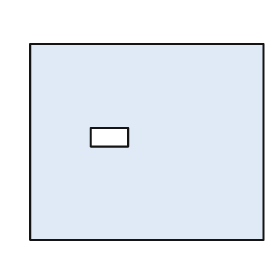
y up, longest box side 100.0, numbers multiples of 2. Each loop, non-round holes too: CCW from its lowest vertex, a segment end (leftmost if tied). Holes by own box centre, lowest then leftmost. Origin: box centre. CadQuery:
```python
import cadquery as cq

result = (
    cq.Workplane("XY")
    .moveTo(-50.0, -42.0)
    .lineTo(50.0, -42.0)
    .lineTo(50.0, 42.0)
    .lineTo(-50.0, 42.0)
    .close()
    .moveTo(-24.0, -2.0)
    .lineTo(-8.0, -2.0)
    .lineTo(-8.0, 6.0)
    .lineTo(-24.0, 6.0)
    .close()
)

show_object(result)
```